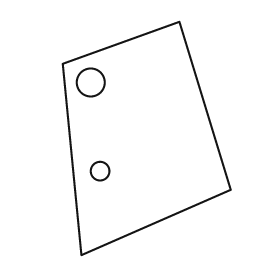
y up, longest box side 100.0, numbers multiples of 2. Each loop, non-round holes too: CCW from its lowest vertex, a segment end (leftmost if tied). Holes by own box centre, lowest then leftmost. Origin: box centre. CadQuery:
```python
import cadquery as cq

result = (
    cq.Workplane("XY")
    .moveTo(-28.0, -50.0)
    .lineTo(36.0, -22.0)
    .lineTo(14.0, 50.0)
    .lineTo(-36.0, 32.0)
    .close()
    .moveTo(-20.0, -14.0)
    .circle(4.0)
    .moveTo(-24.0, 24.0)
    .circle(6.0)
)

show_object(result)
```